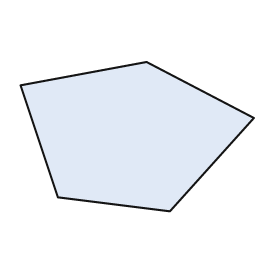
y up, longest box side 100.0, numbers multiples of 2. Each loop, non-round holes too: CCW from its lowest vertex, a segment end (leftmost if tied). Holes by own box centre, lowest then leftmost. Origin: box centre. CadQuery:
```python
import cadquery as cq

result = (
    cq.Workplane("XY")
    .moveTo(14.0, -32.0)
    .lineTo(50.0, 8.0)
    .lineTo(4.0, 32.0)
    .lineTo(-50.0, 22.0)
    .lineTo(-34.0, -26.0)
    .close()
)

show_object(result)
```